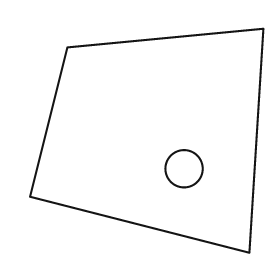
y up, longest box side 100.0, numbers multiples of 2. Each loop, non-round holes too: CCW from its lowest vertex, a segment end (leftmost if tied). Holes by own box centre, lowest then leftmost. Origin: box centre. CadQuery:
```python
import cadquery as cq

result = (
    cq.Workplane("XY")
    .moveTo(44.0, -48.0)
    .lineTo(50.0, 48.0)
    .lineTo(-34.0, 40.0)
    .lineTo(-50.0, -24.0)
    .close()
    .moveTo(16.0, -12.0)
    .circle(8.0)
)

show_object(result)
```